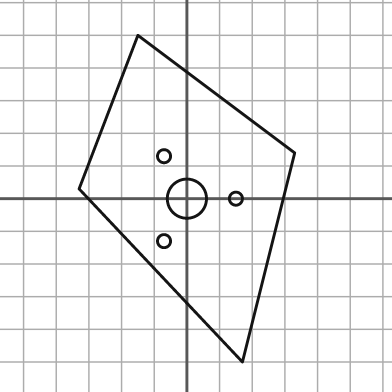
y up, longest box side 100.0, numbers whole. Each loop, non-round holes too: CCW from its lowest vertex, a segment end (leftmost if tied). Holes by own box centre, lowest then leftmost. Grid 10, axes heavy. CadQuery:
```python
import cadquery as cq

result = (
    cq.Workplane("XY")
    .moveTo(17.0, -50.0)
    .lineTo(33.0, 14.0)
    .lineTo(-15.0, 50.0)
    .lineTo(-33.0, 3.0)
    .close()
    .moveTo(-7.0, -13.0)
    .circle(2.0)
    .moveTo(0.0, 0.0)
    .circle(6.0)
    .moveTo(15.0, 0.0)
    .circle(2.0)
    .moveTo(-7.0, 13.0)
    .circle(2.0)
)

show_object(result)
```